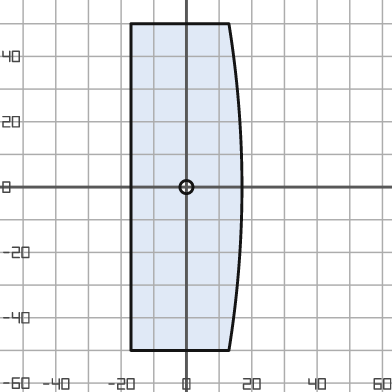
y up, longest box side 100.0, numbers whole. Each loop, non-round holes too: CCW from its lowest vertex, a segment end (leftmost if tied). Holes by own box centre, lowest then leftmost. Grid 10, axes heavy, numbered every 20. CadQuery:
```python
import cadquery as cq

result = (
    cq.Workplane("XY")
    .moveTo(-17.0, -50.0)
    .lineTo(13.0, -50.0)
    .threePointArc((17.0, 0.0), (13.0, 50.0))
    .lineTo(-17.0, 50.0)
    .close()
    .moveTo(0.0, 0.0)
    .circle(2.0)
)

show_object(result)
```